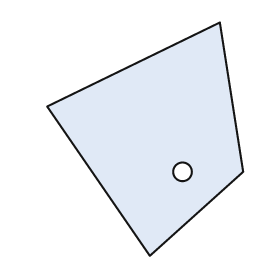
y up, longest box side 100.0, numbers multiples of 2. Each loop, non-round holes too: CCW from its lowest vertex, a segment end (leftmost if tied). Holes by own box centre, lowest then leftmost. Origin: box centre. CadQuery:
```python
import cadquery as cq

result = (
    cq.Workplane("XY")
    .moveTo(2.0, -50.0)
    .lineTo(42.0, -14.0)
    .lineTo(32.0, 50.0)
    .lineTo(-42.0, 14.0)
    .close()
    .moveTo(16.0, -14.0)
    .circle(4.0)
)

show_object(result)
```